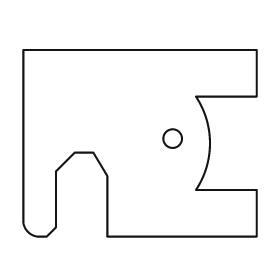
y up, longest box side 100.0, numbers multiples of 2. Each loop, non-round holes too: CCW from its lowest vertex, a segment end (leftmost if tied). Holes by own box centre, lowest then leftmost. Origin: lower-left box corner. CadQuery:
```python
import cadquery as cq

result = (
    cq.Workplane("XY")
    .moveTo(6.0, 0.0)
    .lineTo(10.0, 0.0)
    .lineTo(14.0, 4.0)
    .lineTo(14.0, 28.0)
    .lineTo(22.0, 36.0)
    .lineTo(30.0, 36.0)
    .lineTo(36.0, 26.0)
    .lineTo(36.0, 0.0)
    .lineTo(100.0, 0.0)
    .lineTo(100.0, 20.0)
    .lineTo(74.0, 20.0)
    .threePointArc((80.0, 40.0), (74.0, 60.0))
    .lineTo(100.0, 60.0)
    .lineTo(100.0, 80.0)
    .lineTo(0.0, 80.0)
    .lineTo(0.0, 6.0)
    .threePointArc((2.0, 2.0), (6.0, 0.0))
    .close()
    .moveTo(64.0, 42.0)
    .circle(4.0)
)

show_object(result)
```